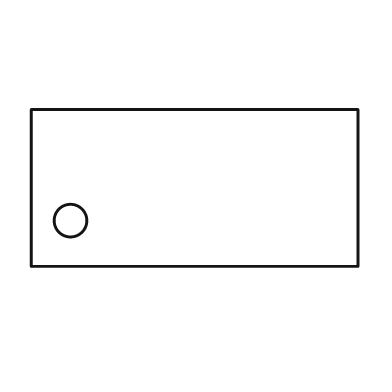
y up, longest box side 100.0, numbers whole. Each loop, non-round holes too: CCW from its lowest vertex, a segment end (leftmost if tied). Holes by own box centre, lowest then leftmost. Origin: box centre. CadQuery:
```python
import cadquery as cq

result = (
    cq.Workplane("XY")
    .moveTo(-50.0, -24.0)
    .lineTo(50.0, -24.0)
    .lineTo(50.0, 24.0)
    .lineTo(-50.0, 24.0)
    .close()
    .moveTo(-38.0, -10.0)
    .circle(5.0)
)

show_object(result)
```